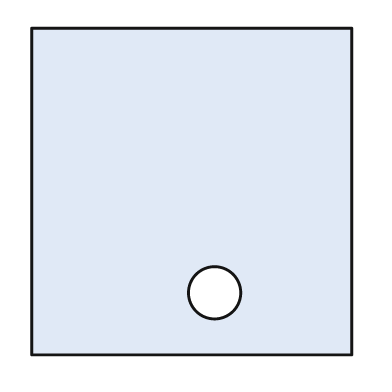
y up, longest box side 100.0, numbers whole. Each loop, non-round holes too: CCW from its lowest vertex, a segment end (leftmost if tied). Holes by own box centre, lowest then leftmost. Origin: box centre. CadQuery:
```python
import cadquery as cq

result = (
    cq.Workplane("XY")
    .moveTo(-49.0, -50.0)
    .lineTo(49.0, -50.0)
    .lineTo(49.0, 50.0)
    .lineTo(-49.0, 50.0)
    .close()
    .moveTo(7.0, -31.0)
    .circle(8.0)
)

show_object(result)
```